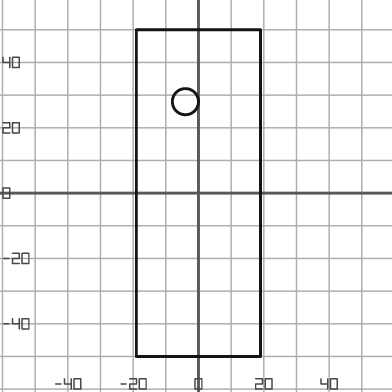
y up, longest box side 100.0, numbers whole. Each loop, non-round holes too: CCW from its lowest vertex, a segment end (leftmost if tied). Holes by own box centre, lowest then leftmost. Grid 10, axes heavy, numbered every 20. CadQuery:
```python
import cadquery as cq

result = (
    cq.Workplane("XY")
    .moveTo(-19.0, -50.0)
    .lineTo(19.0, -50.0)
    .lineTo(19.0, 50.0)
    .lineTo(-19.0, 50.0)
    .close()
    .moveTo(-4.0, 28.0)
    .circle(4.0)
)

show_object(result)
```